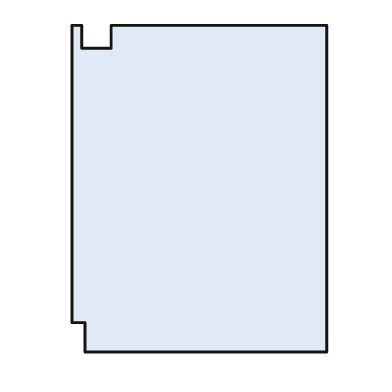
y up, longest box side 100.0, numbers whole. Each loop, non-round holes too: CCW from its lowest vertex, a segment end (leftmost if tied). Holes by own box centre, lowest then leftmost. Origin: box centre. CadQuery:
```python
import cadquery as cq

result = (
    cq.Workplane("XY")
    .moveTo(-35.0, -50.0)
    .lineTo(39.0, -50.0)
    .lineTo(39.0, 50.0)
    .lineTo(-27.0, 50.0)
    .lineTo(-27.0, 43.0)
    .lineTo(-36.0, 43.0)
    .lineTo(-36.0, 50.0)
    .lineTo(-39.0, 50.0)
    .lineTo(-39.0, -41.0)
    .lineTo(-35.0, -41.0)
    .close()
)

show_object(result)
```